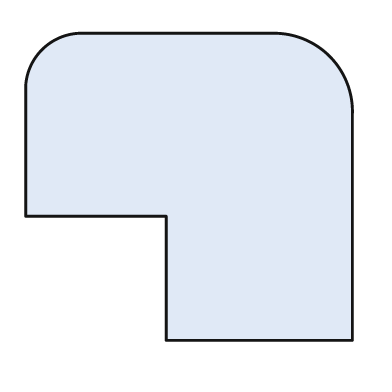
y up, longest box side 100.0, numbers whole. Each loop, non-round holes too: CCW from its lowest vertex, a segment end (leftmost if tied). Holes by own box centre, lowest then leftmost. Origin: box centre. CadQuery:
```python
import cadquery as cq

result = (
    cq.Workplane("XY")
    .moveTo(-7.0, -47.0)
    .lineTo(50.0, -47.0)
    .lineTo(50.0, 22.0)
    .threePointArc((43.0, 40.0), (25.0, 47.0))
    .lineTo(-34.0, 47.0)
    .threePointArc((-45.0, 42.0), (-50.0, 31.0))
    .lineTo(-50.0, -9.0)
    .lineTo(-7.0, -9.0)
    .close()
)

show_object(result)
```